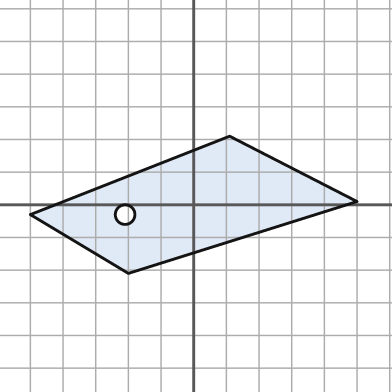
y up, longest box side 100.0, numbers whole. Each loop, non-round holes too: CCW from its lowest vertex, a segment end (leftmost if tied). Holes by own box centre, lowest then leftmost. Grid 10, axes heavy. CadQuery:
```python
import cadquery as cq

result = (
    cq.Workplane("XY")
    .moveTo(-20.0, -21.0)
    .lineTo(50.0, 1.0)
    .lineTo(11.0, 21.0)
    .lineTo(-50.0, -3.0)
    .close()
    .moveTo(-21.0, -3.0)
    .circle(3.0)
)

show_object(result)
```